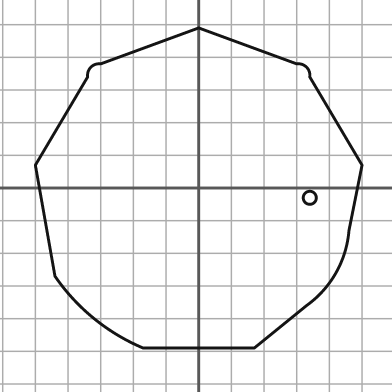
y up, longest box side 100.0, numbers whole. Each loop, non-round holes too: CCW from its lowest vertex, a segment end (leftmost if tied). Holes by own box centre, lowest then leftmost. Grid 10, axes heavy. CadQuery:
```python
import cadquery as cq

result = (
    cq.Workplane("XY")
    .moveTo(-17.0, -49.0)
    .lineTo(17.0, -49.0)
    .lineTo(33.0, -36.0)
    .threePointArc((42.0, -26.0), (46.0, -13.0))
    .lineTo(50.0, 7.0)
    .lineTo(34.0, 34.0)
    .threePointArc((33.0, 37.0), (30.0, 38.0))
    .lineTo(0.0, 49.0)
    .lineTo(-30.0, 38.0)
    .threePointArc((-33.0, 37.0), (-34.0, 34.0))
    .lineTo(-50.0, 7.0)
    .lineTo(-44.0, -27.0)
    .threePointArc((-32.0, -40.0), (-17.0, -49.0))
    .close()
    .moveTo(34.0, -3.0)
    .circle(2.0)
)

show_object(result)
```